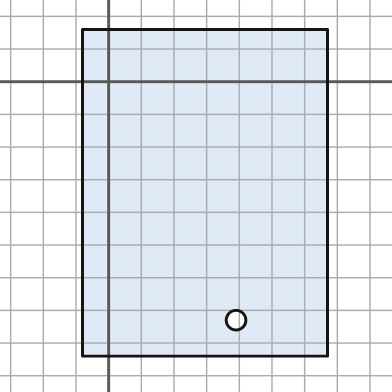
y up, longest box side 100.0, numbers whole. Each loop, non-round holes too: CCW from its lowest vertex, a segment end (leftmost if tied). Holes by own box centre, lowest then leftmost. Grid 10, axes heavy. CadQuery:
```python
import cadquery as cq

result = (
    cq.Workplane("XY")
    .moveTo(-8.0, -84.0)
    .lineTo(67.0, -84.0)
    .lineTo(67.0, 16.0)
    .lineTo(-8.0, 16.0)
    .close()
    .moveTo(39.0, -73.0)
    .circle(3.0)
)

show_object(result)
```